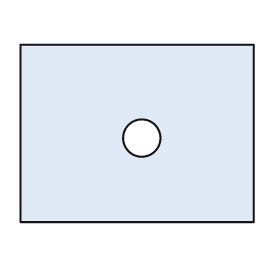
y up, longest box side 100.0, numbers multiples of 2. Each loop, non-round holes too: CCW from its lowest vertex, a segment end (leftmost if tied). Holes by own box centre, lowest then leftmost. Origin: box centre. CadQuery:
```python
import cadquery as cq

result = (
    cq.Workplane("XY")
    .moveTo(-50.0, -38.0)
    .lineTo(50.0, -38.0)
    .lineTo(50.0, 38.0)
    .lineTo(-50.0, 38.0)
    .close()
    .moveTo(2.0, -2.0)
    .circle(8.0)
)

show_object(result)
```